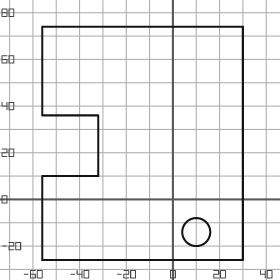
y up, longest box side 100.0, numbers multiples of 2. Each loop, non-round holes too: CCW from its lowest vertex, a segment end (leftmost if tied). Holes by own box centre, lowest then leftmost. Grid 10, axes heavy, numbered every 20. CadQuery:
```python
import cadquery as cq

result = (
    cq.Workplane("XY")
    .moveTo(-56.0, -26.0)
    .lineTo(30.0, -26.0)
    .lineTo(30.0, 74.0)
    .lineTo(-56.0, 74.0)
    .lineTo(-56.0, 36.0)
    .lineTo(-32.0, 36.0)
    .lineTo(-32.0, 10.0)
    .lineTo(-56.0, 10.0)
    .close()
    .moveTo(10.0, -14.0)
    .circle(6.0)
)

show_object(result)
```